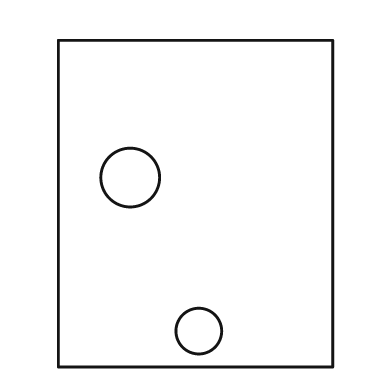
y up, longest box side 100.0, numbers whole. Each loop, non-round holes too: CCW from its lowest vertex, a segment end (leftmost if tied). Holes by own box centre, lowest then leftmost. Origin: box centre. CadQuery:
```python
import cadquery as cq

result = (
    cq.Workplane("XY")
    .moveTo(-42.0, -50.0)
    .lineTo(42.0, -50.0)
    .lineTo(42.0, 50.0)
    .lineTo(-42.0, 50.0)
    .close()
    .moveTo(1.0, -39.0)
    .circle(7.0)
    .moveTo(-20.0, 8.0)
    .circle(9.0)
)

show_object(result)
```